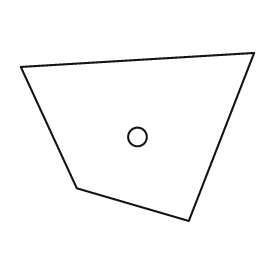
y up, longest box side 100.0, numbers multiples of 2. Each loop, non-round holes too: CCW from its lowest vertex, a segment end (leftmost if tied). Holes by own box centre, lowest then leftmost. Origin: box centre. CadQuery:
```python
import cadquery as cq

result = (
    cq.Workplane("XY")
    .moveTo(22.0, -36.0)
    .lineTo(50.0, 36.0)
    .lineTo(-50.0, 30.0)
    .lineTo(-26.0, -22.0)
    .close()
    .moveTo(0.0, 0.0)
    .circle(4.0)
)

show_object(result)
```